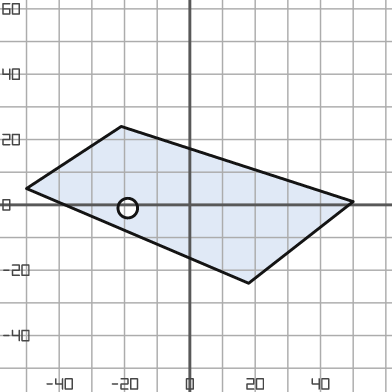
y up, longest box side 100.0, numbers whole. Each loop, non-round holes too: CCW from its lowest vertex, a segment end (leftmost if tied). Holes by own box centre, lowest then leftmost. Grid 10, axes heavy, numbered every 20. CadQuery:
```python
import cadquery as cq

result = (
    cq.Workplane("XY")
    .moveTo(18.0, -24.0)
    .lineTo(50.0, 1.0)
    .lineTo(-21.0, 24.0)
    .lineTo(-50.0, 5.0)
    .close()
    .moveTo(-19.0, -1.0)
    .circle(3.0)
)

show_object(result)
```